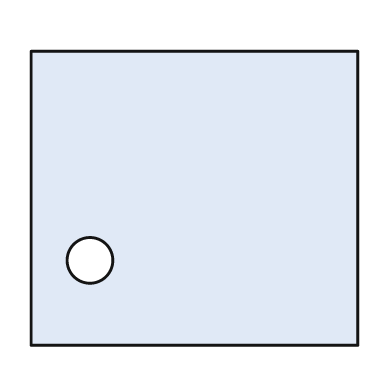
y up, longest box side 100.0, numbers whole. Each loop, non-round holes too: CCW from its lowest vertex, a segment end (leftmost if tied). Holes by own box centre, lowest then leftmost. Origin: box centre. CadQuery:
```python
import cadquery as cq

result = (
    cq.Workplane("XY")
    .moveTo(-50.0, -45.0)
    .lineTo(50.0, -45.0)
    .lineTo(50.0, 45.0)
    .lineTo(-50.0, 45.0)
    .close()
    .moveTo(-32.0, -19.0)
    .circle(7.0)
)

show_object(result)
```